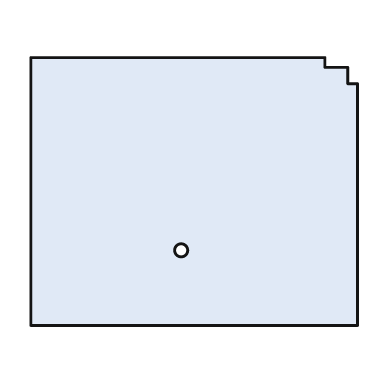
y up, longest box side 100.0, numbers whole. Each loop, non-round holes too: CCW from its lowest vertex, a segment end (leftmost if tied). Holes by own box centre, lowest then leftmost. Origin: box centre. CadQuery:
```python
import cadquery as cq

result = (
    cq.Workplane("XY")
    .moveTo(-50.0, -41.0)
    .lineTo(50.0, -41.0)
    .lineTo(50.0, 33.0)
    .lineTo(47.0, 33.0)
    .lineTo(47.0, 38.0)
    .lineTo(40.0, 38.0)
    .lineTo(40.0, 41.0)
    .lineTo(-50.0, 41.0)
    .close()
    .moveTo(-4.0, -18.0)
    .circle(2.0)
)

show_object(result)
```